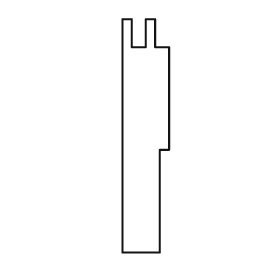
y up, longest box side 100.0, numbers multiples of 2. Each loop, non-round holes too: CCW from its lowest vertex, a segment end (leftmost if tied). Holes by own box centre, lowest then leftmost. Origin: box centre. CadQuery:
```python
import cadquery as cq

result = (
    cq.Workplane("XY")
    .moveTo(-10.0, -50.0)
    .lineTo(6.0, -50.0)
    .lineTo(6.0, -6.0)
    .lineTo(10.0, -6.0)
    .lineTo(10.0, 38.0)
    .lineTo(4.0, 38.0)
    .lineTo(4.0, 50.0)
    .lineTo(0.0, 50.0)
    .lineTo(0.0, 38.0)
    .lineTo(-6.0, 38.0)
    .lineTo(-6.0, 50.0)
    .lineTo(-10.0, 50.0)
    .close()
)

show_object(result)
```